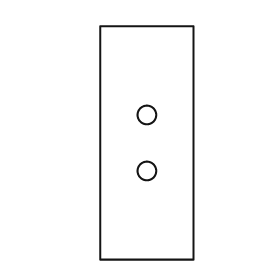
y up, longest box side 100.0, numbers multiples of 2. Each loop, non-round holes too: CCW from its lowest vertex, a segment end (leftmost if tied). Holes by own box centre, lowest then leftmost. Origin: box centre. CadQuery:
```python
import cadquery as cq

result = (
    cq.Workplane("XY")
    .moveTo(-20.0, -50.0)
    .lineTo(20.0, -50.0)
    .lineTo(20.0, 50.0)
    .lineTo(-20.0, 50.0)
    .close()
    .moveTo(0.0, -12.0)
    .circle(4.0)
    .moveTo(0.0, 12.0)
    .circle(4.0)
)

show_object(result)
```